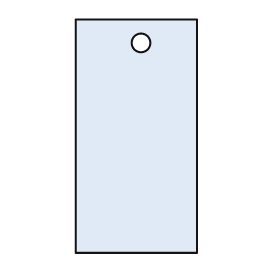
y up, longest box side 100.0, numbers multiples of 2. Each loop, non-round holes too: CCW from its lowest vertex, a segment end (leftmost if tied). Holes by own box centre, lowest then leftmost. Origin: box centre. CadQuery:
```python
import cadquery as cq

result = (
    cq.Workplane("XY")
    .moveTo(-26.0, -50.0)
    .lineTo(26.0, -50.0)
    .lineTo(26.0, 50.0)
    .lineTo(-26.0, 50.0)
    .close()
    .moveTo(2.0, 40.0)
    .circle(4.0)
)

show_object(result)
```